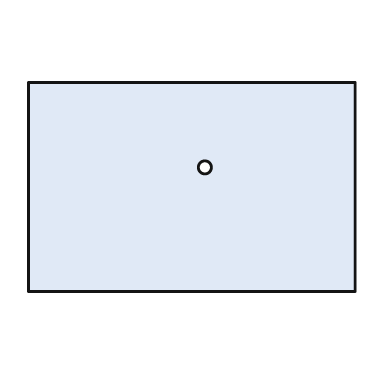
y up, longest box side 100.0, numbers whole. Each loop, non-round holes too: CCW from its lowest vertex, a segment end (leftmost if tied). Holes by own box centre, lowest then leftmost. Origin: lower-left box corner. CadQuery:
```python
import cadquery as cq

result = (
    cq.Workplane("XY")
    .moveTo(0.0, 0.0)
    .lineTo(100.0, 0.0)
    .lineTo(100.0, 64.0)
    .lineTo(0.0, 64.0)
    .close()
    .moveTo(54.0, 38.0)
    .circle(2.0)
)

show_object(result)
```